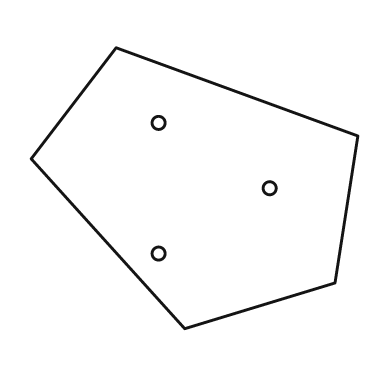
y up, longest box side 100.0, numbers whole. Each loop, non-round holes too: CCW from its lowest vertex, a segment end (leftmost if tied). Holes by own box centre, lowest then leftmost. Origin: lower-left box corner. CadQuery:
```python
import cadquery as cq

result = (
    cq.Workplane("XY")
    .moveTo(47.0, 0.0)
    .lineTo(93.0, 14.0)
    .lineTo(100.0, 59.0)
    .lineTo(26.0, 86.0)
    .lineTo(0.0, 52.0)
    .close()
    .moveTo(39.0, 23.0)
    .circle(2.0)
    .moveTo(73.0, 43.0)
    .circle(2.0)
    .moveTo(39.0, 63.0)
    .circle(2.0)
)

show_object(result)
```